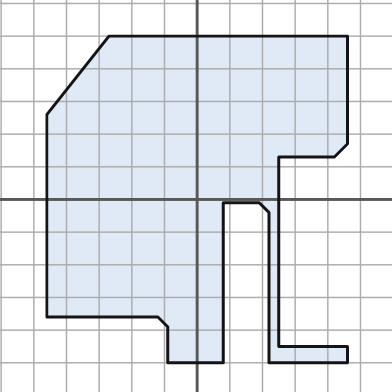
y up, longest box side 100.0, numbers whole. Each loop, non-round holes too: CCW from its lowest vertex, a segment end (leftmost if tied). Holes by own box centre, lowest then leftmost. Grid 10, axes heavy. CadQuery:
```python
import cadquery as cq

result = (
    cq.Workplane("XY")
    .moveTo(-9.0, -50.0)
    .lineTo(8.0, -50.0)
    .lineTo(8.0, -1.0)
    .lineTo(19.0, -1.0)
    .lineTo(22.0, -4.0)
    .lineTo(22.0, -50.0)
    .lineTo(46.0, -50.0)
    .lineTo(46.0, -45.0)
    .lineTo(25.0, -45.0)
    .lineTo(25.0, 13.0)
    .lineTo(42.0, 13.0)
    .lineTo(46.0, 17.0)
    .lineTo(46.0, 50.0)
    .lineTo(-27.0, 50.0)
    .lineTo(-46.0, 26.0)
    .lineTo(-46.0, -36.0)
    .lineTo(-12.0, -36.0)
    .lineTo(-9.0, -39.0)
    .close()
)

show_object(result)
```